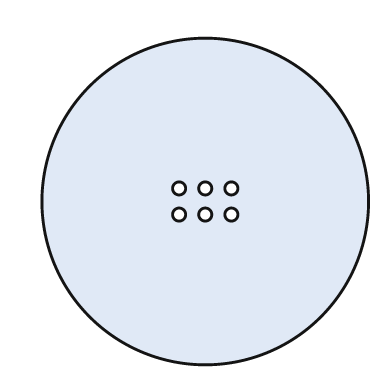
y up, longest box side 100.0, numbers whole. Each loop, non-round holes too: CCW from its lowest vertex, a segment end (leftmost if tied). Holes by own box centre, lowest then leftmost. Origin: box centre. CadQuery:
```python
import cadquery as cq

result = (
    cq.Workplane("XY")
    .moveTo(0.0, 0.0)
    .circle(50.0)
    .moveTo(-8.0, -4.0)
    .circle(2.0)
    .moveTo(0.0, -4.0)
    .circle(2.0)
    .moveTo(8.0, -4.0)
    .circle(2.0)
    .moveTo(-8.0, 4.0)
    .circle(2.0)
    .moveTo(0.0, 4.0)
    .circle(2.0)
    .moveTo(8.0, 4.0)
    .circle(2.0)
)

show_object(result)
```